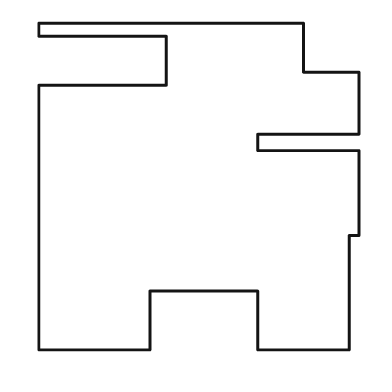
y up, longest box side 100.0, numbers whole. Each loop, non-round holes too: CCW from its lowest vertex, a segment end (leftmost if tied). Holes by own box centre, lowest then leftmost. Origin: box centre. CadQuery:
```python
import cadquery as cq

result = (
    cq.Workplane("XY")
    .moveTo(-49.0, -50.0)
    .lineTo(-15.0, -50.0)
    .lineTo(-15.0, -32.0)
    .lineTo(18.0, -32.0)
    .lineTo(18.0, -50.0)
    .lineTo(46.0, -50.0)
    .lineTo(46.0, -15.0)
    .lineTo(49.0, -15.0)
    .lineTo(49.0, 11.0)
    .lineTo(18.0, 11.0)
    .lineTo(18.0, 16.0)
    .lineTo(49.0, 16.0)
    .lineTo(49.0, 35.0)
    .lineTo(32.0, 35.0)
    .lineTo(32.0, 50.0)
    .lineTo(-49.0, 50.0)
    .lineTo(-49.0, 46.0)
    .lineTo(-10.0, 46.0)
    .lineTo(-10.0, 31.0)
    .lineTo(-49.0, 31.0)
    .close()
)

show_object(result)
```